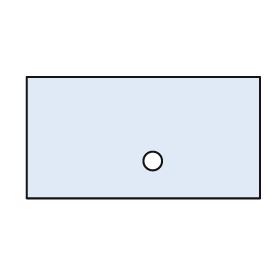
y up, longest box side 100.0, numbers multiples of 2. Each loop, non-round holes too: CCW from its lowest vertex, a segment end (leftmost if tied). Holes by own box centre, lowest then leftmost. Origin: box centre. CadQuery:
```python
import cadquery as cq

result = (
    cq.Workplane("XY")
    .moveTo(-50.0, -26.0)
    .lineTo(50.0, -26.0)
    .lineTo(50.0, 26.0)
    .lineTo(-50.0, 26.0)
    .close()
    .moveTo(4.0, -10.0)
    .circle(4.0)
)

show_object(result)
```